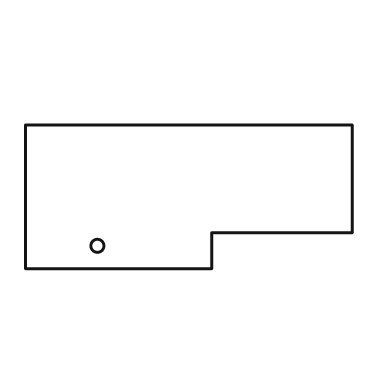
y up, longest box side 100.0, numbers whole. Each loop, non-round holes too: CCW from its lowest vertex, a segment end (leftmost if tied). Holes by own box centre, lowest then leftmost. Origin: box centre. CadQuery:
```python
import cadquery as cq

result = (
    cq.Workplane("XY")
    .moveTo(-50.0, -22.0)
    .lineTo(7.0, -22.0)
    .lineTo(7.0, -11.0)
    .lineTo(50.0, -11.0)
    .lineTo(50.0, 22.0)
    .lineTo(-50.0, 22.0)
    .close()
    .moveTo(-28.0, -15.0)
    .circle(2.0)
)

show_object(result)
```